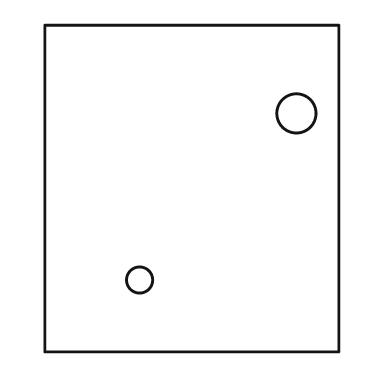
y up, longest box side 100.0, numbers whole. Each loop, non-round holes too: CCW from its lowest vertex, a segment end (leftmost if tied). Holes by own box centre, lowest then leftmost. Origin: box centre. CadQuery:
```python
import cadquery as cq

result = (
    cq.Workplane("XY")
    .moveTo(-45.0, -50.0)
    .lineTo(45.0, -50.0)
    .lineTo(45.0, 50.0)
    .lineTo(-45.0, 50.0)
    .close()
    .moveTo(-16.0, -28.0)
    .circle(4.0)
    .moveTo(32.0, 23.0)
    .circle(6.0)
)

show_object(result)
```